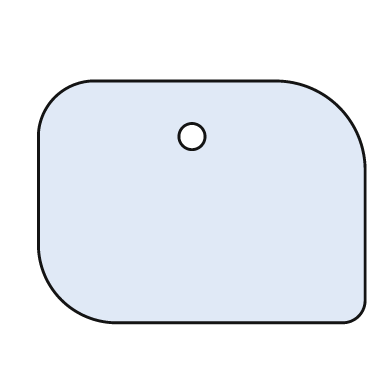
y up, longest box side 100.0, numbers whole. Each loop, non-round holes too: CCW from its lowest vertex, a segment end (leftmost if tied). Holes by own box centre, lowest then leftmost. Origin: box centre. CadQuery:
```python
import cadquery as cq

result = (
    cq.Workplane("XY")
    .moveTo(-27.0, -37.0)
    .lineTo(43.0, -37.0)
    .threePointArc((48.0, -35.0), (50.0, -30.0))
    .lineTo(50.0, 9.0)
    .threePointArc((42.0, 29.0), (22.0, 37.0))
    .lineTo(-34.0, 37.0)
    .threePointArc((-45.0, 32.0), (-50.0, 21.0))
    .lineTo(-50.0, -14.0)
    .threePointArc((-43.0, -30.0), (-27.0, -37.0))
    .close()
    .moveTo(-3.0, 20.0)
    .circle(4.0)
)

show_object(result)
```